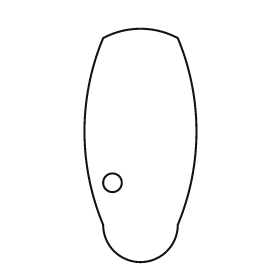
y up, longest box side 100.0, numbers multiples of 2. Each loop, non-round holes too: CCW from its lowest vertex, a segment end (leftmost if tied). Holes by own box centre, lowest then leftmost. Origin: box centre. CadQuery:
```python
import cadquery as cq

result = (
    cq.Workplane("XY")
    .moveTo(-16.0, -34.0)
    .threePointArc((0.0, -50.0), (16.0, -34.0))
    .threePointArc((24.0, 6.0), (16.0, 46.0))
    .threePointArc((0.0, 50.0), (-16.0, 46.0))
    .threePointArc((-24.0, 6.0), (-16.0, -34.0))
    .close()
    .moveTo(-12.0, -16.0)
    .circle(4.0)
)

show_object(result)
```